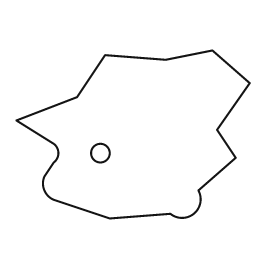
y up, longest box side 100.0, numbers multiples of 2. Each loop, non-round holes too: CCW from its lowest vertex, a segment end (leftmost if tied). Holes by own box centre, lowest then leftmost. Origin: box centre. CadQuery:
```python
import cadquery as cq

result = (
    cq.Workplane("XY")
    .moveTo(-10.0, -36.0)
    .lineTo(16.0, -34.0)
    .threePointArc((26.0, -34.0), (28.0, -24.0))
    .lineTo(44.0, -10.0)
    .lineTo(36.0, 2.0)
    .lineTo(50.0, 22.0)
    .lineTo(34.0, 36.0)
    .lineTo(14.0, 32.0)
    .lineTo(-12.0, 34.0)
    .lineTo(-24.0, 16.0)
    .lineTo(-50.0, 6.0)
    .lineTo(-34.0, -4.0)
    .threePointArc((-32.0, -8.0), (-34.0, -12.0))
    .lineTo(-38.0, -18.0)
    .threePointArc((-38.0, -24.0), (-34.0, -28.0))
    .close()
    .moveTo(-14.0, -8.0)
    .circle(4.0)
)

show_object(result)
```